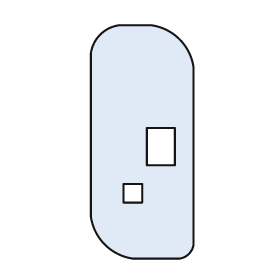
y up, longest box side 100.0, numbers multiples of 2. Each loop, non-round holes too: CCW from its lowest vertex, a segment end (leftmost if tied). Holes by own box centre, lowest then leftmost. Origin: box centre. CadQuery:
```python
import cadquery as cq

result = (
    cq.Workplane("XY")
    .moveTo(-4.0, -50.0)
    .lineTo(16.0, -50.0)
    .threePointArc((20.0, -48.0), (22.0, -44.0))
    .lineTo(22.0, 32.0)
    .threePointArc((16.0, 44.0), (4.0, 50.0))
    .lineTo(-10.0, 50.0)
    .threePointArc((-18.0, 46.0), (-22.0, 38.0))
    .lineTo(-22.0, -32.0)
    .threePointArc((-16.0, -44.0), (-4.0, -50.0))
    .close()
    .moveTo(-8.0, -26.0)
    .lineTo(0.0, -26.0)
    .lineTo(0.0, -18.0)
    .lineTo(-8.0, -18.0)
    .close()
    .moveTo(2.0, -10.0)
    .lineTo(14.0, -10.0)
    .lineTo(14.0, 6.0)
    .lineTo(2.0, 6.0)
    .close()
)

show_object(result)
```